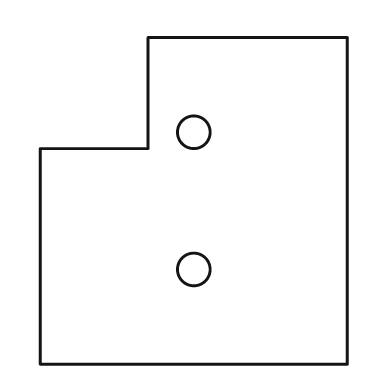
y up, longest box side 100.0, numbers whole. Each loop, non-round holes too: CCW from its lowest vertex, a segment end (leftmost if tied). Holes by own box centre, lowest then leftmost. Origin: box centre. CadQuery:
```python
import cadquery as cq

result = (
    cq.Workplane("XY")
    .moveTo(-47.0, -50.0)
    .lineTo(47.0, -50.0)
    .lineTo(47.0, 50.0)
    .lineTo(-14.0, 50.0)
    .lineTo(-14.0, 16.0)
    .lineTo(-47.0, 16.0)
    .close()
    .moveTo(0.0, -21.0)
    .circle(5.0)
    .moveTo(0.0, 21.0)
    .circle(5.0)
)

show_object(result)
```